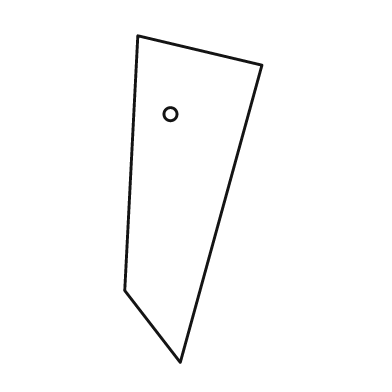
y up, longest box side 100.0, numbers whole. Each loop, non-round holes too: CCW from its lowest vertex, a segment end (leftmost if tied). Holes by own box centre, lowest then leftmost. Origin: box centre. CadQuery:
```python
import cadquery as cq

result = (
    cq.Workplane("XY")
    .moveTo(-4.0, -50.0)
    .lineTo(21.0, 41.0)
    .lineTo(-17.0, 50.0)
    .lineTo(-21.0, -28.0)
    .close()
    .moveTo(-7.0, 26.0)
    .circle(2.0)
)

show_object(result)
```